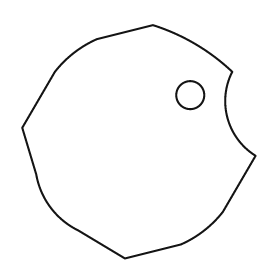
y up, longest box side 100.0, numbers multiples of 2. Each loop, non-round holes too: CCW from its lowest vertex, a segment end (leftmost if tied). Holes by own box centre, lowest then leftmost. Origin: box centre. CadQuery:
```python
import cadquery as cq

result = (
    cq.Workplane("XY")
    .moveTo(-6.0, -50.0)
    .lineTo(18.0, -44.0)
    .threePointArc((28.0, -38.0), (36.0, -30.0))
    .lineTo(50.0, -6.0)
    .threePointArc((38.0, 10.0), (40.0, 30.0))
    .threePointArc((24.0, 42.0), (6.0, 50.0))
    .lineTo(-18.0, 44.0)
    .threePointArc((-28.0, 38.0), (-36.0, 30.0))
    .lineTo(-50.0, 6.0)
    .lineTo(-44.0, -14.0)
    .threePointArc((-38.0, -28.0), (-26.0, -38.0))
    .close()
    .moveTo(22.0, 20.0)
    .circle(6.0)
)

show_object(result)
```